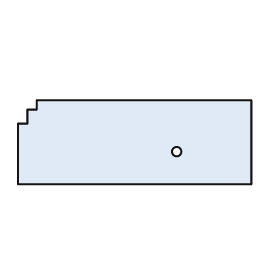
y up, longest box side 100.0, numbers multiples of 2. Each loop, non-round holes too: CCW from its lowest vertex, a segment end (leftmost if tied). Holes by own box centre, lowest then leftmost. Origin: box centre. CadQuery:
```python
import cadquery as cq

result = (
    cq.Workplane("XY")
    .moveTo(-50.0, -18.0)
    .lineTo(50.0, -18.0)
    .lineTo(50.0, 18.0)
    .lineTo(-42.0, 18.0)
    .lineTo(-42.0, 14.0)
    .lineTo(-46.0, 14.0)
    .lineTo(-46.0, 8.0)
    .lineTo(-50.0, 8.0)
    .close()
    .moveTo(18.0, -4.0)
    .circle(2.0)
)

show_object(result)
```